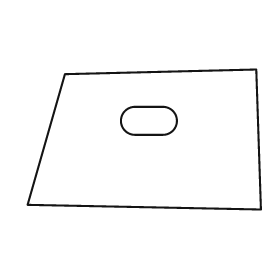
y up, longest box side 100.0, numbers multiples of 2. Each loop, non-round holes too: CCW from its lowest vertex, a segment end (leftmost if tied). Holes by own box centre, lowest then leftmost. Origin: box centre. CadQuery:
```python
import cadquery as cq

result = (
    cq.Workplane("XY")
    .moveTo(50.0, -30.0)
    .lineTo(48.0, 30.0)
    .lineTo(-34.0, 28.0)
    .lineTo(-50.0, -28.0)
    .close()
    .moveTo(-4.0, 2.0)
    .lineTo(8.0, 2.0)
    .threePointArc((14.0, 8.0), (8.0, 14.0))
    .lineTo(-4.0, 14.0)
    .threePointArc((-10.0, 8.0), (-4.0, 2.0))
    .close()
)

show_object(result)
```